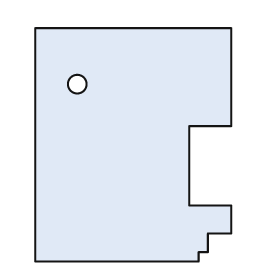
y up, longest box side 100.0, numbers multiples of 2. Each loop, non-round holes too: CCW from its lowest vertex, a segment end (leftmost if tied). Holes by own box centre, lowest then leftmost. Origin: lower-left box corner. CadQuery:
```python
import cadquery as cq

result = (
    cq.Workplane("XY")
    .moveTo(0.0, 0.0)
    .lineTo(70.0, 0.0)
    .lineTo(70.0, 4.0)
    .lineTo(74.0, 4.0)
    .lineTo(74.0, 12.0)
    .lineTo(84.0, 12.0)
    .lineTo(84.0, 24.0)
    .lineTo(66.0, 24.0)
    .lineTo(66.0, 58.0)
    .lineTo(84.0, 58.0)
    .lineTo(84.0, 100.0)
    .lineTo(0.0, 100.0)
    .close()
    .moveTo(18.0, 76.0)
    .circle(4.0)
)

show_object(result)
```